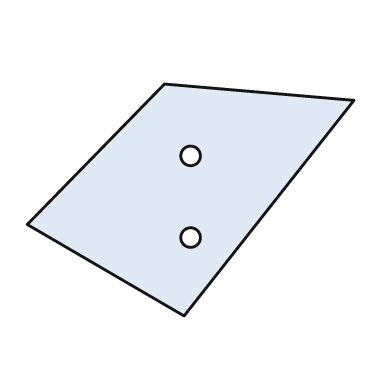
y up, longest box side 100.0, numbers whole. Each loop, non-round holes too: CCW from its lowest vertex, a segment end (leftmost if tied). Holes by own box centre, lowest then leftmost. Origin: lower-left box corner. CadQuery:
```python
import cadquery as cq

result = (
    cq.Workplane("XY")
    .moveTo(48.0, 0.0)
    .lineTo(100.0, 66.0)
    .lineTo(42.0, 71.0)
    .lineTo(0.0, 28.0)
    .close()
    .moveTo(50.0, 24.0)
    .circle(3.0)
    .moveTo(50.0, 49.0)
    .circle(3.0)
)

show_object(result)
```